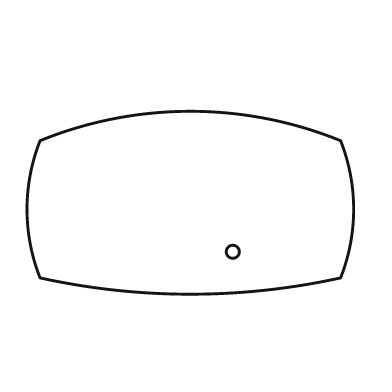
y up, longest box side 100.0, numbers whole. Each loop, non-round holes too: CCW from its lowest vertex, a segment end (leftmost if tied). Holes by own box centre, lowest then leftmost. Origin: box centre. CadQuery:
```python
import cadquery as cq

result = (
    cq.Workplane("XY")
    .moveTo(-46.0, -23.0)
    .threePointArc((0.0, -28.0), (46.0, -23.0))
    .threePointArc((50.0, -2.0), (46.0, 19.0))
    .threePointArc((0.0, 28.0), (-46.0, 19.0))
    .threePointArc((-50.0, -2.0), (-46.0, -23.0))
    .close()
    .moveTo(13.0, -15.0)
    .circle(2.0)
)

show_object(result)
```